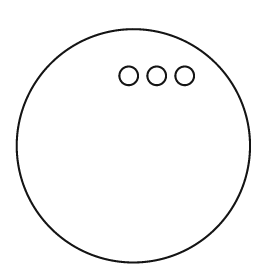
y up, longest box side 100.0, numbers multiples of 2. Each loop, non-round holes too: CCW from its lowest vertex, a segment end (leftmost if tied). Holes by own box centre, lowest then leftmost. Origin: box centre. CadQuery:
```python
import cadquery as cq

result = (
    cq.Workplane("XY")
    .moveTo(0.0, 0.0)
    .circle(50.0)
    .moveTo(-2.0, 30.0)
    .circle(4.0)
    .moveTo(10.0, 30.0)
    .circle(4.0)
    .moveTo(22.0, 30.0)
    .circle(4.0)
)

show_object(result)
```